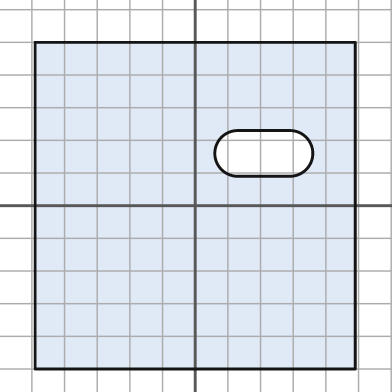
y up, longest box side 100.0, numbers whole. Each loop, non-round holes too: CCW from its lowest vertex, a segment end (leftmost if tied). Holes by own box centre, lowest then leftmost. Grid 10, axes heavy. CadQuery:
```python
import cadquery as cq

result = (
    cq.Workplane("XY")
    .moveTo(-49.0, -50.0)
    .lineTo(49.0, -50.0)
    .lineTo(49.0, 50.0)
    .lineTo(-49.0, 50.0)
    .close()
    .moveTo(13.0, 9.0)
    .lineTo(29.0, 9.0)
    .threePointArc((36.0, 16.0), (29.0, 23.0))
    .lineTo(13.0, 23.0)
    .threePointArc((6.0, 16.0), (13.0, 9.0))
    .close()
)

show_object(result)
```